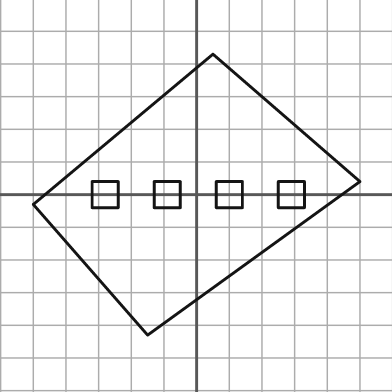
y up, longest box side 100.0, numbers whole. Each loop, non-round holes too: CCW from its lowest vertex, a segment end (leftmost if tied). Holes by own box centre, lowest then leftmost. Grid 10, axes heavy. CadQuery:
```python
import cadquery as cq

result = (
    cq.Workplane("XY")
    .moveTo(-15.0, -43.0)
    .lineTo(50.0, 4.0)
    .lineTo(5.0, 43.0)
    .lineTo(-50.0, -3.0)
    .close()
    .moveTo(-32.0, -4.0)
    .lineTo(-24.0, -4.0)
    .lineTo(-24.0, 4.0)
    .lineTo(-32.0, 4.0)
    .close()
    .moveTo(-13.0, -4.0)
    .lineTo(-5.0, -4.0)
    .lineTo(-5.0, 4.0)
    .lineTo(-13.0, 4.0)
    .close()
    .moveTo(6.0, -4.0)
    .lineTo(14.0, -4.0)
    .lineTo(14.0, 4.0)
    .lineTo(6.0, 4.0)
    .close()
    .moveTo(25.0, -4.0)
    .lineTo(33.0, -4.0)
    .lineTo(33.0, 4.0)
    .lineTo(25.0, 4.0)
    .close()
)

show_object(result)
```